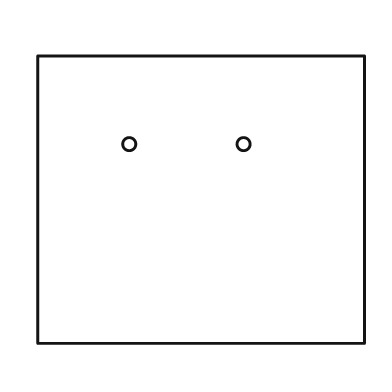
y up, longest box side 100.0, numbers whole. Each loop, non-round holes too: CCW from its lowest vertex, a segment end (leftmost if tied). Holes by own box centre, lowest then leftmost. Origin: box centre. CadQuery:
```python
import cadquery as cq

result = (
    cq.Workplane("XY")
    .moveTo(-50.0, -44.0)
    .lineTo(50.0, -44.0)
    .lineTo(50.0, 44.0)
    .lineTo(-50.0, 44.0)
    .close()
    .moveTo(-22.0, 17.0)
    .circle(2.0)
    .moveTo(13.0, 17.0)
    .circle(2.0)
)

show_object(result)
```